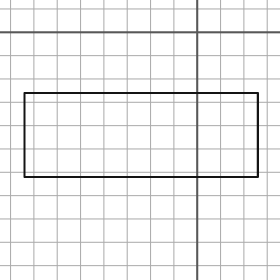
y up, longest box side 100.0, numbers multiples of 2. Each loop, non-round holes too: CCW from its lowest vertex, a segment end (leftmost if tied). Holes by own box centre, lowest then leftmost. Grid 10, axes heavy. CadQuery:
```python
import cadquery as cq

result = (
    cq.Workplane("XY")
    .moveTo(-74.0, -62.0)
    .lineTo(26.0, -62.0)
    .lineTo(26.0, -26.0)
    .lineTo(-74.0, -26.0)
    .close()
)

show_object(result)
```